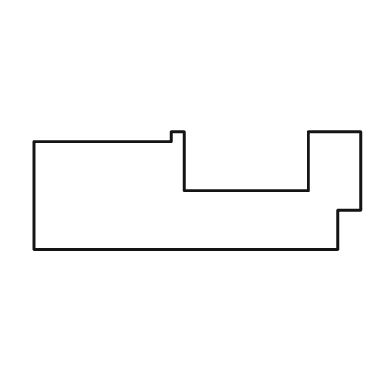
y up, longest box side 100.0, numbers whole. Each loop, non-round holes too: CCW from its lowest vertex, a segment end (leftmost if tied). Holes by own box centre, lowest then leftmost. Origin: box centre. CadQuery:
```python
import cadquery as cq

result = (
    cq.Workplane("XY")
    .moveTo(-50.0, -18.0)
    .lineTo(43.0, -18.0)
    .lineTo(43.0, -6.0)
    .lineTo(50.0, -6.0)
    .lineTo(50.0, 18.0)
    .lineTo(34.0, 18.0)
    .lineTo(34.0, 0.0)
    .lineTo(-4.0, 0.0)
    .lineTo(-4.0, 18.0)
    .lineTo(-8.0, 18.0)
    .lineTo(-8.0, 15.0)
    .lineTo(-50.0, 15.0)
    .close()
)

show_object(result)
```